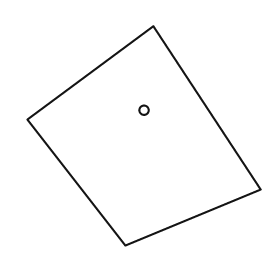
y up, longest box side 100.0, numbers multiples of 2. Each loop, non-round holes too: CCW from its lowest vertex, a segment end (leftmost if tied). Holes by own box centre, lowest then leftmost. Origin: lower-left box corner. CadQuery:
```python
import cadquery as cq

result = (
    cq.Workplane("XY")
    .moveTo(42.0, 0.0)
    .lineTo(100.0, 24.0)
    .lineTo(54.0, 94.0)
    .lineTo(0.0, 54.0)
    .close()
    .moveTo(50.0, 58.0)
    .circle(2.0)
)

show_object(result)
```